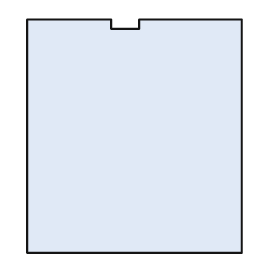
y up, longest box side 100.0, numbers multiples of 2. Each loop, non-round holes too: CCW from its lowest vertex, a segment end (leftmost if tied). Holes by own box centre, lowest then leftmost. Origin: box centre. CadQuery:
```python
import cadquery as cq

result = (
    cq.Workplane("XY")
    .moveTo(-46.0, -50.0)
    .lineTo(46.0, -50.0)
    .lineTo(46.0, 50.0)
    .lineTo(2.0, 50.0)
    .lineTo(2.0, 46.0)
    .lineTo(-10.0, 46.0)
    .lineTo(-10.0, 50.0)
    .lineTo(-46.0, 50.0)
    .close()
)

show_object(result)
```